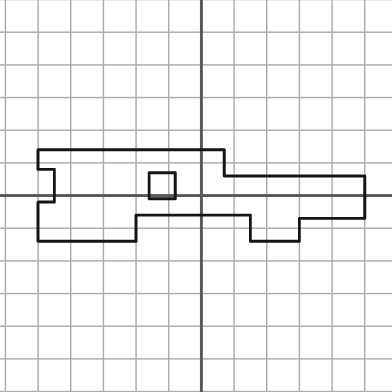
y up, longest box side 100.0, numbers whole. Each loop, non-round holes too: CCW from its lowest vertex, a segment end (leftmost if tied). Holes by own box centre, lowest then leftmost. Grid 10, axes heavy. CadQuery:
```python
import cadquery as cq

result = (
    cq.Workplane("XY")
    .moveTo(-50.0, -14.0)
    .lineTo(-20.0, -14.0)
    .lineTo(-20.0, -6.0)
    .lineTo(15.0, -6.0)
    .lineTo(15.0, -14.0)
    .lineTo(30.0, -14.0)
    .lineTo(30.0, -7.0)
    .lineTo(50.0, -7.0)
    .lineTo(50.0, 6.0)
    .lineTo(7.0, 6.0)
    .lineTo(7.0, 14.0)
    .lineTo(-50.0, 14.0)
    .lineTo(-50.0, 8.0)
    .lineTo(-45.0, 8.0)
    .lineTo(-45.0, -2.0)
    .lineTo(-50.0, -2.0)
    .close()
    .moveTo(-16.0, -1.0)
    .lineTo(-8.0, -1.0)
    .lineTo(-8.0, 7.0)
    .lineTo(-16.0, 7.0)
    .close()
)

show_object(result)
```